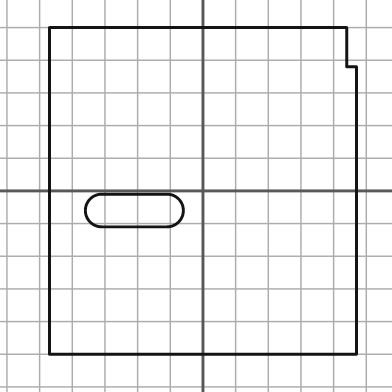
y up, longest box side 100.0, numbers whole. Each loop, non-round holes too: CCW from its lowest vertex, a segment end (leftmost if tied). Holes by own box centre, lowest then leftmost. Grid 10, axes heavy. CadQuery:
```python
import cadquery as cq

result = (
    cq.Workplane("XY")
    .moveTo(-47.0, -50.0)
    .lineTo(47.0, -50.0)
    .lineTo(47.0, 38.0)
    .lineTo(44.0, 38.0)
    .lineTo(44.0, 50.0)
    .lineTo(-47.0, 50.0)
    .close()
    .moveTo(-31.0, -11.0)
    .lineTo(-11.0, -11.0)
    .threePointArc((-6.0, -6.0), (-11.0, -1.0))
    .lineTo(-31.0, -1.0)
    .threePointArc((-36.0, -6.0), (-31.0, -11.0))
    .close()
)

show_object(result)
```